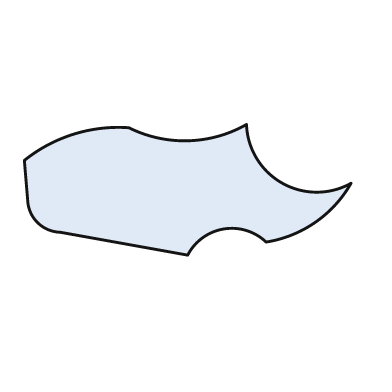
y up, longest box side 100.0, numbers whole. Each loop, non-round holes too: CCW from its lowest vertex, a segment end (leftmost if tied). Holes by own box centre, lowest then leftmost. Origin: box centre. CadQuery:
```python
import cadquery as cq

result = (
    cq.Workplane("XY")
    .moveTo(0.0, -20.0)
    .threePointArc((11.0, -12.0), (24.0, -16.0))
    .threePointArc((39.0, -10.0), (50.0, 2.0))
    .threePointArc((29.0, 2.0), (18.0, 20.0))
    .threePointArc((0.0, 15.0), (-18.0, 19.0))
    .threePointArc((-35.0, 17.0), (-50.0, 9.0))
    .lineTo(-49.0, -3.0)
    .threePointArc((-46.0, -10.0), (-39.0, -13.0))
    .close()
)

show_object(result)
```